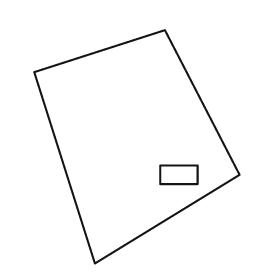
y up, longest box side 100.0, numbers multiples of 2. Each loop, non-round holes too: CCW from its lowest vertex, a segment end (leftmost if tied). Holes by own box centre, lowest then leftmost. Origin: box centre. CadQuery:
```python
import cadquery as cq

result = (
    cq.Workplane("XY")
    .moveTo(-18.0, -50.0)
    .lineTo(44.0, -12.0)
    .lineTo(12.0, 50.0)
    .lineTo(-44.0, 32.0)
    .close()
    .moveTo(10.0, -16.0)
    .lineTo(26.0, -16.0)
    .lineTo(26.0, -8.0)
    .lineTo(10.0, -8.0)
    .close()
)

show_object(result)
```